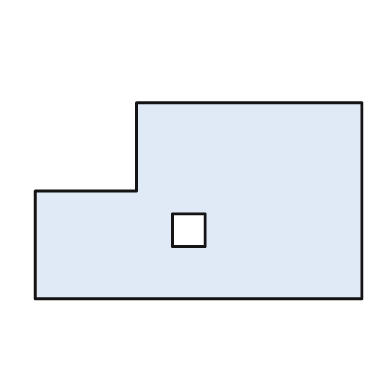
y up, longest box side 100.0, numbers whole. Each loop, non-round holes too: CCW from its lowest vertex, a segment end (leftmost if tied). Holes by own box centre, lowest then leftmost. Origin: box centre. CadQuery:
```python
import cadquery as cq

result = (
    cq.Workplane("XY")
    .moveTo(-50.0, -30.0)
    .lineTo(50.0, -30.0)
    .lineTo(50.0, 30.0)
    .lineTo(-19.0, 30.0)
    .lineTo(-19.0, 3.0)
    .lineTo(-50.0, 3.0)
    .close()
    .moveTo(-8.0, -14.0)
    .lineTo(2.0, -14.0)
    .lineTo(2.0, -4.0)
    .lineTo(-8.0, -4.0)
    .close()
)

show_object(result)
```